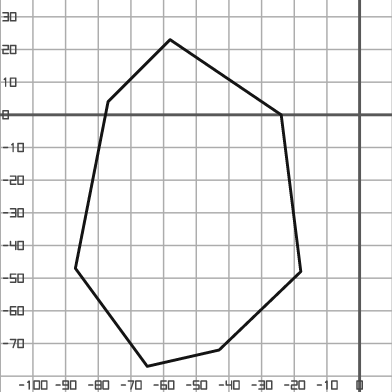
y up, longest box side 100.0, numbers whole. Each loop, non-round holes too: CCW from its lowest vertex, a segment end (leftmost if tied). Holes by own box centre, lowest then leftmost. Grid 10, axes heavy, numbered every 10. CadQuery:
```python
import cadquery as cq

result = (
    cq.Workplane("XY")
    .moveTo(-65.0, -77.0)
    .lineTo(-43.0, -72.0)
    .lineTo(-18.0, -48.0)
    .lineTo(-24.0, 0.0)
    .lineTo(-58.0, 23.0)
    .lineTo(-77.0, 4.0)
    .lineTo(-87.0, -47.0)
    .close()
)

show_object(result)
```